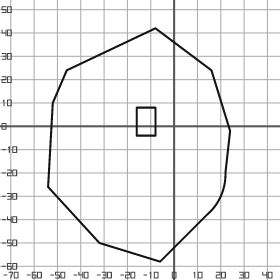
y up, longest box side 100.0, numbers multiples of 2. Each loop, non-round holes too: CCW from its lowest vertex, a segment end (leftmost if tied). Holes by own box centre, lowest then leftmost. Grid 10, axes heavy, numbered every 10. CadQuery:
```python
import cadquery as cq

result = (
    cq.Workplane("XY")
    .moveTo(-6.0, -58.0)
    .lineTo(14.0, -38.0)
    .threePointArc((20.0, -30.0), (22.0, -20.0))
    .lineTo(24.0, -2.0)
    .lineTo(16.0, 24.0)
    .lineTo(-8.0, 42.0)
    .lineTo(-46.0, 24.0)
    .lineTo(-52.0, 10.0)
    .lineTo(-54.0, -26.0)
    .lineTo(-32.0, -50.0)
    .close()
    .moveTo(-16.0, -4.0)
    .lineTo(-8.0, -4.0)
    .lineTo(-8.0, 8.0)
    .lineTo(-16.0, 8.0)
    .close()
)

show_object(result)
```